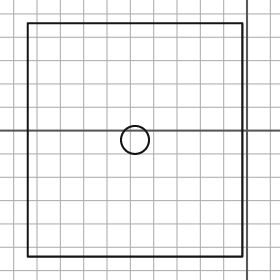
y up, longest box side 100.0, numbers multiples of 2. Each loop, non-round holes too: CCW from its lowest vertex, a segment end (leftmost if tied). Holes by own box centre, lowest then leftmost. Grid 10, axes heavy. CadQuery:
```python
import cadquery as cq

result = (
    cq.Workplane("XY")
    .moveTo(-94.0, -54.0)
    .lineTo(-2.0, -54.0)
    .lineTo(-2.0, 46.0)
    .lineTo(-94.0, 46.0)
    .close()
    .moveTo(-48.0, -4.0)
    .circle(6.0)
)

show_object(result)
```